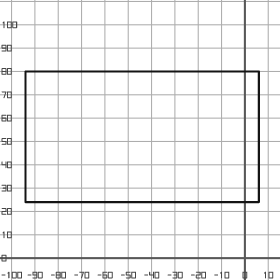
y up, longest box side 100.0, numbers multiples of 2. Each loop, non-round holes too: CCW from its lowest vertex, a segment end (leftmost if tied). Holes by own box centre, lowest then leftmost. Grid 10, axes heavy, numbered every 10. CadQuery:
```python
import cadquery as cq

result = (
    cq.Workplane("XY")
    .moveTo(-94.0, 24.0)
    .lineTo(6.0, 24.0)
    .lineTo(6.0, 80.0)
    .lineTo(-94.0, 80.0)
    .close()
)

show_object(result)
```